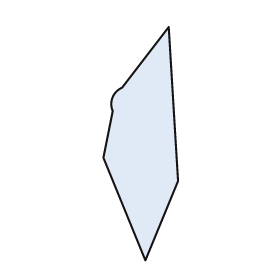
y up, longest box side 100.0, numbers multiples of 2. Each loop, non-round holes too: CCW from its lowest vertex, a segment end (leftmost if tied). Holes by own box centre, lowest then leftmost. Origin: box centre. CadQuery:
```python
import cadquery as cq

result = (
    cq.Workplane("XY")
    .moveTo(2.0, -50.0)
    .lineTo(16.0, -16.0)
    .lineTo(12.0, 50.0)
    .lineTo(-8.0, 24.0)
    .threePointArc((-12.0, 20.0), (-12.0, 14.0))
    .lineTo(-16.0, -6.0)
    .close()
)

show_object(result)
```